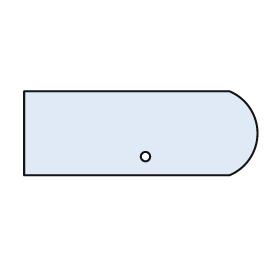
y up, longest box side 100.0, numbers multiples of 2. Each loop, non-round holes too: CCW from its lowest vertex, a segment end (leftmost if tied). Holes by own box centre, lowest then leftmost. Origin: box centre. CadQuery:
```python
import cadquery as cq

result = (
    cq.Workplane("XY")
    .moveTo(-50.0, -18.0)
    .lineTo(38.0, -18.0)
    .threePointArc((50.0, 0.0), (38.0, 18.0))
    .lineTo(-50.0, 18.0)
    .close()
    .moveTo(2.0, -10.0)
    .circle(2.0)
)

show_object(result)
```